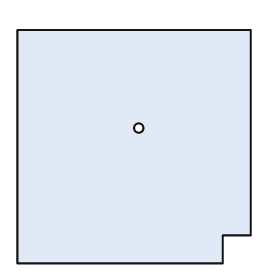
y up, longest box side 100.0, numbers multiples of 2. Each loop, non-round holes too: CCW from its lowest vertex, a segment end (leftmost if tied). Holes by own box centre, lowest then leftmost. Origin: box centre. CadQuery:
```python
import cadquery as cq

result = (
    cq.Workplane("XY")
    .moveTo(-50.0, -50.0)
    .lineTo(38.0, -50.0)
    .lineTo(38.0, -38.0)
    .lineTo(50.0, -38.0)
    .lineTo(50.0, 50.0)
    .lineTo(-50.0, 50.0)
    .close()
    .moveTo(2.0, 8.0)
    .circle(2.0)
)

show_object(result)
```